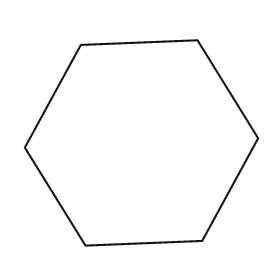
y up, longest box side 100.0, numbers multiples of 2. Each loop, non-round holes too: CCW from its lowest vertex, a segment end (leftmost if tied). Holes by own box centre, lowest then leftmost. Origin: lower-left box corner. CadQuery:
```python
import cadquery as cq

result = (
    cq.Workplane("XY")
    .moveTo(26.0, 0.0)
    .lineTo(76.0, 2.0)
    .lineTo(100.0, 46.0)
    .lineTo(74.0, 88.0)
    .lineTo(24.0, 86.0)
    .lineTo(0.0, 42.0)
    .close()
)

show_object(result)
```